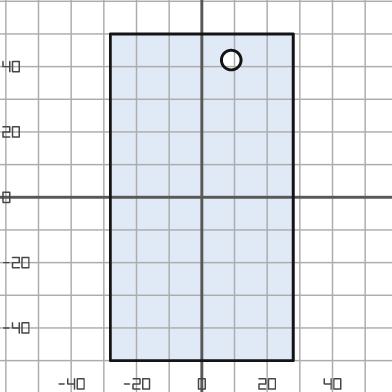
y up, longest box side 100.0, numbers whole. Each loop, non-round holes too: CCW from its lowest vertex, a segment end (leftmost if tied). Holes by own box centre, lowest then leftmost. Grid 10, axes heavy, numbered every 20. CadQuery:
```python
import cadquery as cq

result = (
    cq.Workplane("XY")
    .moveTo(-28.0, -50.0)
    .lineTo(28.0, -50.0)
    .lineTo(28.0, 50.0)
    .lineTo(-28.0, 50.0)
    .close()
    .moveTo(9.0, 42.0)
    .circle(3.0)
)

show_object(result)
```